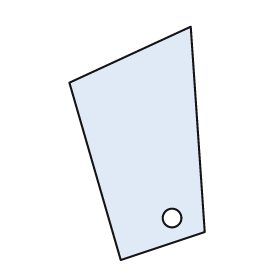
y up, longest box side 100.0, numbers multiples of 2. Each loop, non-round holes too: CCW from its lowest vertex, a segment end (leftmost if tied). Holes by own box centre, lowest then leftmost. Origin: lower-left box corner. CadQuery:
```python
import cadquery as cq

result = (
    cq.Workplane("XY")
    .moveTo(22.0, 0.0)
    .lineTo(58.0, 12.0)
    .lineTo(52.0, 100.0)
    .lineTo(0.0, 76.0)
    .close()
    .moveTo(44.0, 18.0)
    .circle(4.0)
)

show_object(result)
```